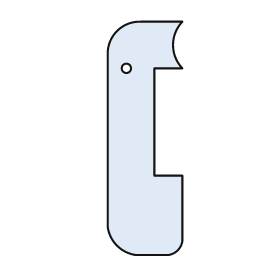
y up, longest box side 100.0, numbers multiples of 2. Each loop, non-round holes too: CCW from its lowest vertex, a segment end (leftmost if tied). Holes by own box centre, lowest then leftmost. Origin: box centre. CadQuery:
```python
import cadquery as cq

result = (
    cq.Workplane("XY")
    .moveTo(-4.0, -50.0)
    .lineTo(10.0, -50.0)
    .threePointArc((14.0, -48.0), (16.0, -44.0))
    .lineTo(16.0, -16.0)
    .lineTo(4.0, -16.0)
    .lineTo(4.0, 30.0)
    .lineTo(16.0, 30.0)
    .threePointArc((12.0, 40.0), (16.0, 50.0))
    .lineTo(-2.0, 50.0)
    .threePointArc((-12.0, 46.0), (-16.0, 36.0))
    .lineTo(-16.0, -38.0)
    .threePointArc((-12.0, -46.0), (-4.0, -50.0))
    .close()
    .moveTo(-8.0, 30.0)
    .circle(2.0)
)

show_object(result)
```